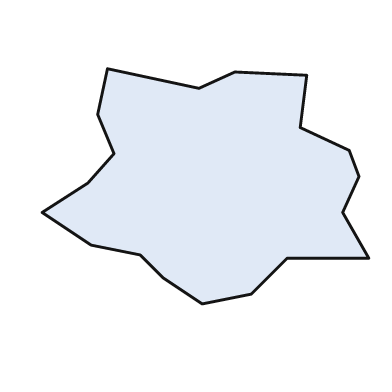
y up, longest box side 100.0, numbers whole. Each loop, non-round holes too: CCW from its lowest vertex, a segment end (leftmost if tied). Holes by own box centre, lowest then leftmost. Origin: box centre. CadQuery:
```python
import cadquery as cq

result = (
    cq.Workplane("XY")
    .moveTo(-1.0, -36.0)
    .lineTo(14.0, -33.0)
    .lineTo(25.0, -22.0)
    .lineTo(50.0, -22.0)
    .lineTo(42.0, -8.0)
    .lineTo(47.0, 3.0)
    .lineTo(44.0, 11.0)
    .lineTo(29.0, 18.0)
    .lineTo(31.0, 34.0)
    .lineTo(9.0, 35.0)
    .lineTo(-2.0, 30.0)
    .lineTo(-30.0, 36.0)
    .lineTo(-33.0, 22.0)
    .lineTo(-28.0, 10.0)
    .lineTo(-36.0, 1.0)
    .lineTo(-50.0, -8.0)
    .lineTo(-35.0, -18.0)
    .lineTo(-20.0, -21.0)
    .lineTo(-13.0, -28.0)
    .close()
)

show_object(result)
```